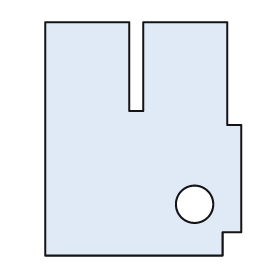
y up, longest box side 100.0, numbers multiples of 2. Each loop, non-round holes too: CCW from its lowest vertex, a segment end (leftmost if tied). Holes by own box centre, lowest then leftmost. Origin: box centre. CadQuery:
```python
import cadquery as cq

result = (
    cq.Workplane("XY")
    .moveTo(-42.0, -50.0)
    .lineTo(34.0, -50.0)
    .lineTo(34.0, -40.0)
    .lineTo(42.0, -40.0)
    .lineTo(42.0, 6.0)
    .lineTo(36.0, 6.0)
    .lineTo(36.0, 50.0)
    .lineTo(0.0, 50.0)
    .lineTo(0.0, 12.0)
    .lineTo(-6.0, 12.0)
    .lineTo(-6.0, 50.0)
    .lineTo(-42.0, 50.0)
    .close()
    .moveTo(22.0, -28.0)
    .circle(8.0)
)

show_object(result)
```